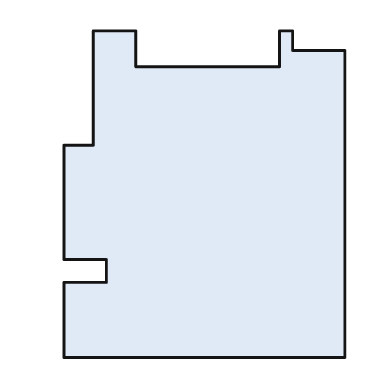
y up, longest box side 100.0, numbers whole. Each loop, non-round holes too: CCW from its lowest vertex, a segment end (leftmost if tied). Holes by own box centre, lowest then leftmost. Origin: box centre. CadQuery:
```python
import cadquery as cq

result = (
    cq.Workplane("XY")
    .moveTo(-43.0, -50.0)
    .lineTo(43.0, -50.0)
    .lineTo(43.0, 44.0)
    .lineTo(27.0, 44.0)
    .lineTo(27.0, 50.0)
    .lineTo(23.0, 50.0)
    .lineTo(23.0, 39.0)
    .lineTo(-21.0, 39.0)
    .lineTo(-21.0, 50.0)
    .lineTo(-34.0, 50.0)
    .lineTo(-34.0, 15.0)
    .lineTo(-43.0, 15.0)
    .lineTo(-43.0, -20.0)
    .lineTo(-30.0, -20.0)
    .lineTo(-30.0, -27.0)
    .lineTo(-43.0, -27.0)
    .close()
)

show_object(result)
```